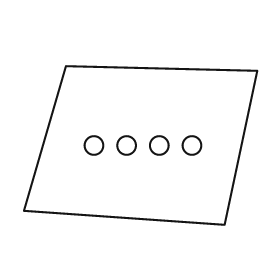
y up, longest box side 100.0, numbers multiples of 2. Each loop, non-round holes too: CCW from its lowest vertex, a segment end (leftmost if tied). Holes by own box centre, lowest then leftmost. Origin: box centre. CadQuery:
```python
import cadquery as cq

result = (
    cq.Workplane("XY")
    .moveTo(36.0, -34.0)
    .lineTo(50.0, 32.0)
    .lineTo(-32.0, 34.0)
    .lineTo(-50.0, -28.0)
    .close()
    .moveTo(-20.0, 0.0)
    .circle(4.0)
    .moveTo(-6.0, 0.0)
    .circle(4.0)
    .moveTo(8.0, 0.0)
    .circle(4.0)
    .moveTo(22.0, 0.0)
    .circle(4.0)
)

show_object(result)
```